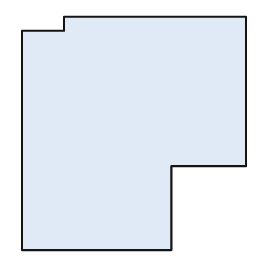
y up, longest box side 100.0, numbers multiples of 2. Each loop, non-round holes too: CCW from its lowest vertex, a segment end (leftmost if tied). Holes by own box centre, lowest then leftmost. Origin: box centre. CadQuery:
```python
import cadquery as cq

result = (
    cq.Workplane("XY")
    .moveTo(-48.0, -50.0)
    .lineTo(16.0, -50.0)
    .lineTo(16.0, -14.0)
    .lineTo(48.0, -14.0)
    .lineTo(48.0, 50.0)
    .lineTo(-30.0, 50.0)
    .lineTo(-30.0, 44.0)
    .lineTo(-48.0, 44.0)
    .close()
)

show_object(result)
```